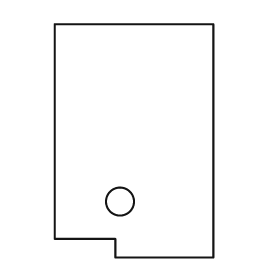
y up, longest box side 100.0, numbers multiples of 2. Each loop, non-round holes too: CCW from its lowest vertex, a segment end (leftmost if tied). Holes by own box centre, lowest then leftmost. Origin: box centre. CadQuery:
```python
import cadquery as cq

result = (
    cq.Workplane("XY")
    .moveTo(-8.0, -50.0)
    .lineTo(34.0, -50.0)
    .lineTo(34.0, 50.0)
    .lineTo(-34.0, 50.0)
    .lineTo(-34.0, -42.0)
    .lineTo(-8.0, -42.0)
    .close()
    .moveTo(-6.0, -26.0)
    .circle(6.0)
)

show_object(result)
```